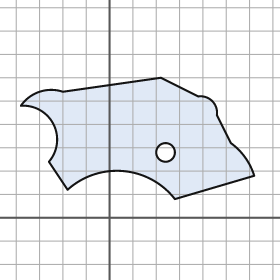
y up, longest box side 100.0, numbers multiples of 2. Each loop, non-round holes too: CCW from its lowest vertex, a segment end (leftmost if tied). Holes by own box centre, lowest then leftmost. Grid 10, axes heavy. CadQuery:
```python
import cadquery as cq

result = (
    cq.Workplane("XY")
    .moveTo(28.0, 8.0)
    .lineTo(62.0, 18.0)
    .threePointArc((58.0, 26.0), (52.0, 32.0))
    .lineTo(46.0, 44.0)
    .threePointArc((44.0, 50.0), (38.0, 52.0))
    .lineTo(22.0, 60.0)
    .lineTo(-20.0, 54.0)
    .threePointArc((-30.0, 54.0), (-38.0, 48.0))
    .threePointArc((-24.0, 40.0), (-26.0, 24.0))
    .lineTo(-18.0, 12.0)
    .threePointArc((6.0, 20.0), (28.0, 8.0))
    .close()
    .moveTo(24.0, 28.0)
    .circle(4.0)
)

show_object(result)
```